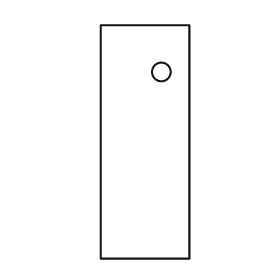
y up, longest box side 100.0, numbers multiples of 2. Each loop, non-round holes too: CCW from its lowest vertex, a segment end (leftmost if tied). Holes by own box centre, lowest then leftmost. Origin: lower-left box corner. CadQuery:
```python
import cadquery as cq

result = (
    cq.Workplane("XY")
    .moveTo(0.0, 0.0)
    .lineTo(38.0, 0.0)
    .lineTo(38.0, 100.0)
    .lineTo(0.0, 100.0)
    .close()
    .moveTo(26.0, 80.0)
    .circle(4.0)
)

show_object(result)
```